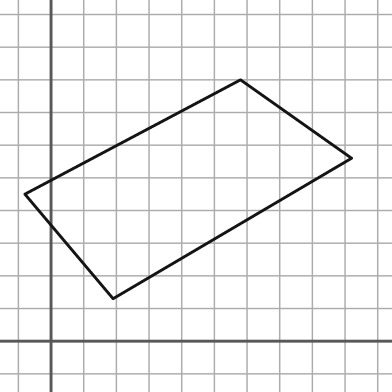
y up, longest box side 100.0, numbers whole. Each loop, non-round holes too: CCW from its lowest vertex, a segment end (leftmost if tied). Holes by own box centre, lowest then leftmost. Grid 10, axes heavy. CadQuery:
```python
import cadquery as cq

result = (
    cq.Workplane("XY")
    .moveTo(19.0, 13.0)
    .lineTo(92.0, 56.0)
    .lineTo(58.0, 80.0)
    .lineTo(-8.0, 45.0)
    .close()
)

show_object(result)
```